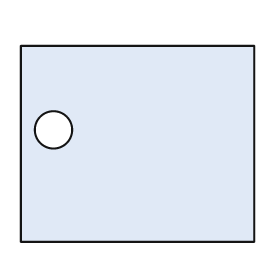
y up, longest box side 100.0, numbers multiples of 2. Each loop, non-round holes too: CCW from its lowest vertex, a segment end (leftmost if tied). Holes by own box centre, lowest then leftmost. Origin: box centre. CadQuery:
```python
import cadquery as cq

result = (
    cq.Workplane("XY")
    .moveTo(-50.0, -42.0)
    .lineTo(50.0, -42.0)
    .lineTo(50.0, 42.0)
    .lineTo(-50.0, 42.0)
    .close()
    .moveTo(-36.0, 6.0)
    .circle(8.0)
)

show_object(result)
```